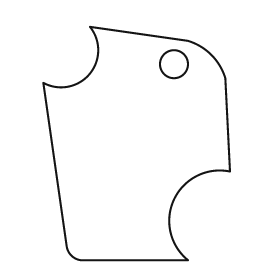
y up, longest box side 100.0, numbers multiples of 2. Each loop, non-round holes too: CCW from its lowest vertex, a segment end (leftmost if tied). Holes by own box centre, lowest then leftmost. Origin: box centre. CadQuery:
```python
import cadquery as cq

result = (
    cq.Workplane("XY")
    .moveTo(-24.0, -50.0)
    .lineTo(22.0, -50.0)
    .threePointArc((16.0, -24.0), (40.0, -12.0))
    .lineTo(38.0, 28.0)
    .threePointArc((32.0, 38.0), (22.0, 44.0))
    .lineTo(-20.0, 50.0)
    .threePointArc((-20.0, 30.0), (-40.0, 26.0))
    .lineTo(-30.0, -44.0)
    .threePointArc((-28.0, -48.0), (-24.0, -50.0))
    .close()
    .moveTo(16.0, 34.0)
    .circle(6.0)
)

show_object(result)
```